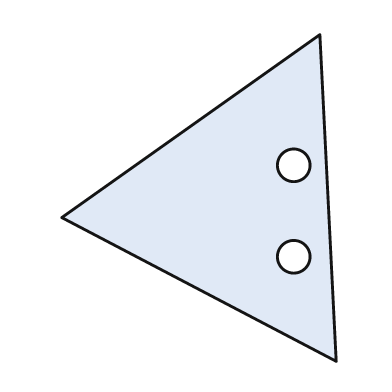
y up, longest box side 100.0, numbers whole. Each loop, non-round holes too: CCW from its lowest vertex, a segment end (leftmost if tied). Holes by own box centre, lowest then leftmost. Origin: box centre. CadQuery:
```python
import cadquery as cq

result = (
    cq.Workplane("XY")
    .moveTo(42.0, -50.0)
    .lineTo(37.0, 50.0)
    .lineTo(-42.0, -6.0)
    .close()
    .moveTo(29.0, -18.0)
    .circle(5.0)
    .moveTo(29.0, 10.0)
    .circle(5.0)
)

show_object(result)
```